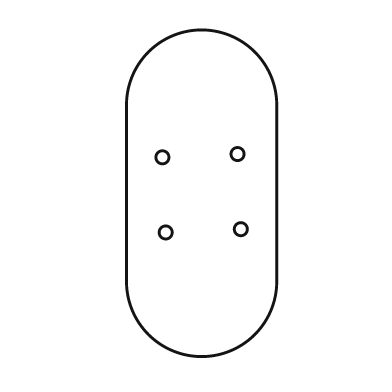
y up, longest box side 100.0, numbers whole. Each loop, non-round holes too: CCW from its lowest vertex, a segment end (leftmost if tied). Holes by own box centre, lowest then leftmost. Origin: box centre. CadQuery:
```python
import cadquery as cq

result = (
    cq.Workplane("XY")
    .moveTo(-23.0, -27.0)
    .threePointArc((0.0, -50.0), (23.0, -27.0))
    .lineTo(23.0, 27.0)
    .threePointArc((0.0, 50.0), (-23.0, 27.0))
    .close()
    .moveTo(-11.0, -12.0)
    .circle(2.0)
    .moveTo(12.0, -11.0)
    .circle(2.0)
    .moveTo(-12.0, 11.0)
    .circle(2.0)
    .moveTo(11.0, 12.0)
    .circle(2.0)
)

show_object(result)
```